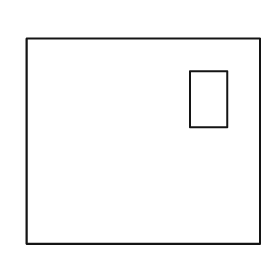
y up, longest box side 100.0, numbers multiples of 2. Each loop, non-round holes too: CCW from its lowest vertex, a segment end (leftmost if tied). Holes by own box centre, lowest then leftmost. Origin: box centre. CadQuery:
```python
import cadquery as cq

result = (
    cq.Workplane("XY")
    .moveTo(-50.0, -44.0)
    .lineTo(50.0, -44.0)
    .lineTo(50.0, 44.0)
    .lineTo(-50.0, 44.0)
    .close()
    .moveTo(20.0, 6.0)
    .lineTo(36.0, 6.0)
    .lineTo(36.0, 30.0)
    .lineTo(20.0, 30.0)
    .close()
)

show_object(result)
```